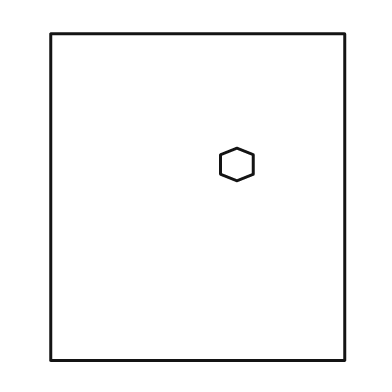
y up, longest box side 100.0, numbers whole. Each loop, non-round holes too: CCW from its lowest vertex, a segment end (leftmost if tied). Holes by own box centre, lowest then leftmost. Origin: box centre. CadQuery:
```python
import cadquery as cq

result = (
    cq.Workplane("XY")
    .moveTo(-45.0, -50.0)
    .lineTo(45.0, -50.0)
    .lineTo(45.0, 50.0)
    .lineTo(-45.0, 50.0)
    .close()
    .moveTo(12.0, 5.0)
    .lineTo(17.0, 7.0)
    .lineTo(17.0, 13.0)
    .lineTo(12.0, 15.0)
    .lineTo(7.0, 13.0)
    .lineTo(7.0, 7.0)
    .close()
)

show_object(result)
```